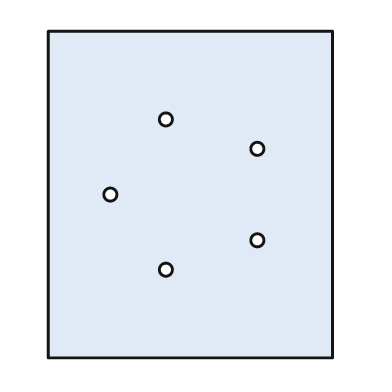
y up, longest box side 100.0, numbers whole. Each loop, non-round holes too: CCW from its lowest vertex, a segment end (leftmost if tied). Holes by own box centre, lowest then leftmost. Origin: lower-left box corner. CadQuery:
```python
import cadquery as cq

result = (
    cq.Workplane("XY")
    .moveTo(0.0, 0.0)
    .lineTo(87.0, 0.0)
    .lineTo(87.0, 100.0)
    .lineTo(0.0, 100.0)
    .close()
    .moveTo(36.0, 27.0)
    .circle(2.0)
    .moveTo(64.0, 36.0)
    .circle(2.0)
    .moveTo(19.0, 50.0)
    .circle(2.0)
    .moveTo(64.0, 64.0)
    .circle(2.0)
    .moveTo(36.0, 73.0)
    .circle(2.0)
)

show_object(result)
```